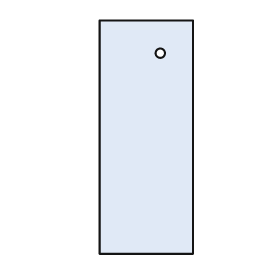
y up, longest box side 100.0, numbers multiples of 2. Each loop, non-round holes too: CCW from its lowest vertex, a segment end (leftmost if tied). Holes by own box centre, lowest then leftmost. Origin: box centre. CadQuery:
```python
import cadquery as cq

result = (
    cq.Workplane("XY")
    .moveTo(-20.0, -50.0)
    .lineTo(20.0, -50.0)
    .lineTo(20.0, 50.0)
    .lineTo(-20.0, 50.0)
    .close()
    .moveTo(6.0, 36.0)
    .circle(2.0)
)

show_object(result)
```